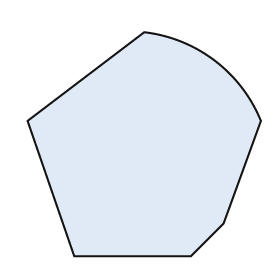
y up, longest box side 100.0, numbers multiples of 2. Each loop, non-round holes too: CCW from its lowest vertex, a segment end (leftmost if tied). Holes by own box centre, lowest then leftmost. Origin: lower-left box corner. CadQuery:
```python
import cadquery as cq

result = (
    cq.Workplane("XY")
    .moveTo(20.0, 0.0)
    .lineTo(70.0, 0.0)
    .lineTo(84.0, 14.0)
    .lineTo(100.0, 58.0)
    .threePointArc((80.0, 84.0), (50.0, 96.0))
    .lineTo(0.0, 58.0)
    .close()
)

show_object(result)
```